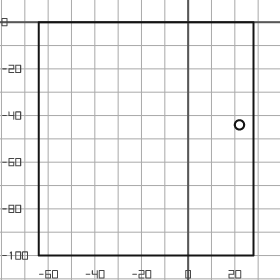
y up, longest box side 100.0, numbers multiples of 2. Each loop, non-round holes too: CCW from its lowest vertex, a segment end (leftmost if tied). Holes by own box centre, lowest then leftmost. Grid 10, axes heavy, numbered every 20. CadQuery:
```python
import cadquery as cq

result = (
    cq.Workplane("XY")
    .moveTo(-64.0, -100.0)
    .lineTo(28.0, -100.0)
    .lineTo(28.0, 0.0)
    .lineTo(-64.0, 0.0)
    .close()
    .moveTo(22.0, -44.0)
    .circle(2.0)
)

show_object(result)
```